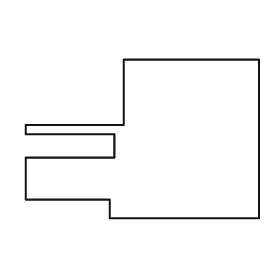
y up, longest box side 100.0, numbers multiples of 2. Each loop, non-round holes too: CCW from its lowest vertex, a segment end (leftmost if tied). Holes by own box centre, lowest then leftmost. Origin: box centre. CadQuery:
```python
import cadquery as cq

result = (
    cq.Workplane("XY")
    .moveTo(-14.0, -34.0)
    .lineTo(50.0, -34.0)
    .lineTo(50.0, 34.0)
    .lineTo(-8.0, 34.0)
    .lineTo(-8.0, 6.0)
    .lineTo(-50.0, 6.0)
    .lineTo(-50.0, 2.0)
    .lineTo(-12.0, 2.0)
    .lineTo(-12.0, -8.0)
    .lineTo(-50.0, -8.0)
    .lineTo(-50.0, -26.0)
    .lineTo(-14.0, -26.0)
    .close()
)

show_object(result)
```